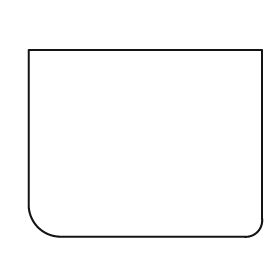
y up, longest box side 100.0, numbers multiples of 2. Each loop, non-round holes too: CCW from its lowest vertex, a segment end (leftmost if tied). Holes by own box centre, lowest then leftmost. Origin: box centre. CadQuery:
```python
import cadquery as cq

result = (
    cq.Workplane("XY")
    .moveTo(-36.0, -40.0)
    .lineTo(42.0, -40.0)
    .threePointArc((48.0, -38.0), (50.0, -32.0))
    .lineTo(50.0, 40.0)
    .lineTo(-50.0, 40.0)
    .lineTo(-50.0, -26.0)
    .threePointArc((-46.0, -36.0), (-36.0, -40.0))
    .close()
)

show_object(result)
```